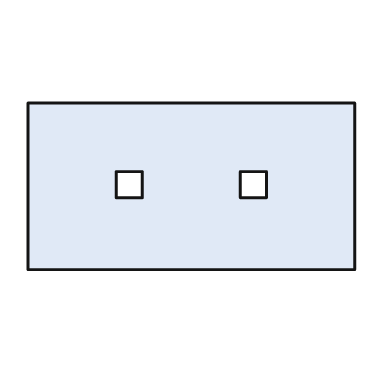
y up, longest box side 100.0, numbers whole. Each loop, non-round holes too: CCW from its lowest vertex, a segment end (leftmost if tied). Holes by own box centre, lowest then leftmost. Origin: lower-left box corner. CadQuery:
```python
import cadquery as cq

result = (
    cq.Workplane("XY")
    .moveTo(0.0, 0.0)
    .lineTo(100.0, 0.0)
    .lineTo(100.0, 51.0)
    .lineTo(0.0, 51.0)
    .close()
    .moveTo(27.0, 22.0)
    .lineTo(35.0, 22.0)
    .lineTo(35.0, 30.0)
    .lineTo(27.0, 30.0)
    .close()
    .moveTo(65.0, 22.0)
    .lineTo(73.0, 22.0)
    .lineTo(73.0, 30.0)
    .lineTo(65.0, 30.0)
    .close()
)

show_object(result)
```